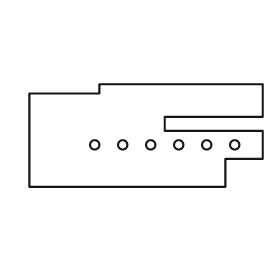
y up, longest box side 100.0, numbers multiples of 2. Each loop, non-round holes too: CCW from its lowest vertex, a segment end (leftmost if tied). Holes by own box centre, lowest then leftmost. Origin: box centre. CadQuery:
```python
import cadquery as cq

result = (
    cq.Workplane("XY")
    .moveTo(-50.0, -22.0)
    .lineTo(34.0, -22.0)
    .lineTo(34.0, -10.0)
    .lineTo(50.0, -10.0)
    .lineTo(50.0, 2.0)
    .lineTo(8.0, 2.0)
    .lineTo(8.0, 8.0)
    .lineTo(50.0, 8.0)
    .lineTo(50.0, 22.0)
    .lineTo(-20.0, 22.0)
    .lineTo(-20.0, 18.0)
    .lineTo(-50.0, 18.0)
    .close()
    .moveTo(-22.0, -4.0)
    .circle(2.0)
    .moveTo(-10.0, -4.0)
    .circle(2.0)
    .moveTo(2.0, -4.0)
    .circle(2.0)
    .moveTo(14.0, -4.0)
    .circle(2.0)
    .moveTo(26.0, -4.0)
    .circle(2.0)
    .moveTo(38.0, -4.0)
    .circle(2.0)
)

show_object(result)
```